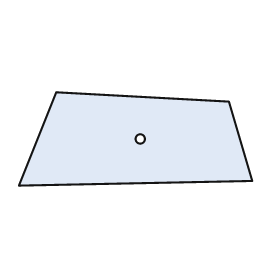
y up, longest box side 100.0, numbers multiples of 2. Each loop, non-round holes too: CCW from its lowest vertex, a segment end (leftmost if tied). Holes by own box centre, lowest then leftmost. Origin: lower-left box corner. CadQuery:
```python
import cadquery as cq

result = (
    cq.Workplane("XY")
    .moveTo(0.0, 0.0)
    .lineTo(100.0, 2.0)
    .lineTo(90.0, 36.0)
    .lineTo(16.0, 40.0)
    .close()
    .moveTo(52.0, 20.0)
    .circle(2.0)
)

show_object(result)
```